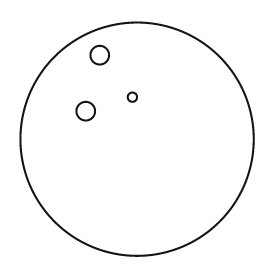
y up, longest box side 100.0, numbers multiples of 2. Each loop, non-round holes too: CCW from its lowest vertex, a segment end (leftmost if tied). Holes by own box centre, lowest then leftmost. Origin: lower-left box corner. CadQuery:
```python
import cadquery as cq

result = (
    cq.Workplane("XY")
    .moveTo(50.0, 50.0)
    .circle(50.0)
    .moveTo(28.0, 62.0)
    .circle(4.0)
    .moveTo(48.0, 68.0)
    .circle(2.0)
    .moveTo(34.0, 86.0)
    .circle(4.0)
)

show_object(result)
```